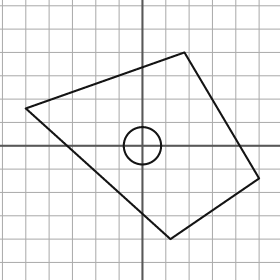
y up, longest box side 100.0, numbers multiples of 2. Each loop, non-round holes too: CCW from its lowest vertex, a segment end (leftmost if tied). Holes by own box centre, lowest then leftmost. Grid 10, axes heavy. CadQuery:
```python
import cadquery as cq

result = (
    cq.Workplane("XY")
    .moveTo(12.0, -40.0)
    .lineTo(50.0, -14.0)
    .lineTo(18.0, 40.0)
    .lineTo(-50.0, 16.0)
    .close()
    .moveTo(0.0, 0.0)
    .circle(8.0)
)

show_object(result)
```